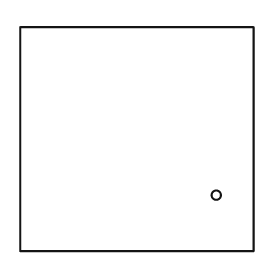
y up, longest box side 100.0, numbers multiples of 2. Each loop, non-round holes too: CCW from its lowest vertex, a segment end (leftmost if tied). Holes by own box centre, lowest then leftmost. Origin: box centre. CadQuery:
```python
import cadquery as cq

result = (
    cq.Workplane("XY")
    .moveTo(-50.0, -48.0)
    .lineTo(50.0, -48.0)
    .lineTo(50.0, 48.0)
    .lineTo(-50.0, 48.0)
    .close()
    .moveTo(34.0, -24.0)
    .circle(2.0)
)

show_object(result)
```